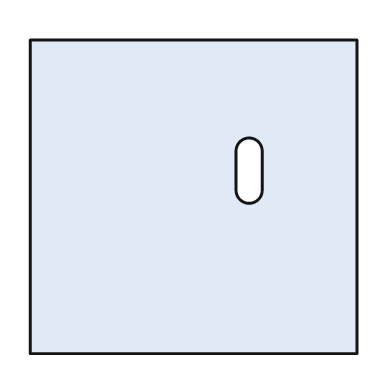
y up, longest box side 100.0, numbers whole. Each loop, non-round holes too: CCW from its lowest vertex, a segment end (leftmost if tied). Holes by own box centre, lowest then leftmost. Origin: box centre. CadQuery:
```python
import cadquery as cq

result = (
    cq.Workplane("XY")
    .moveTo(-50.0, -48.0)
    .lineTo(50.0, -48.0)
    .lineTo(50.0, 48.0)
    .lineTo(-50.0, 48.0)
    .close()
    .moveTo(13.0, 2.0)
    .threePointArc((17.0, -2.0), (21.0, 2.0))
    .lineTo(21.0, 14.0)
    .threePointArc((17.0, 18.0), (13.0, 14.0))
    .close()
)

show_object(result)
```